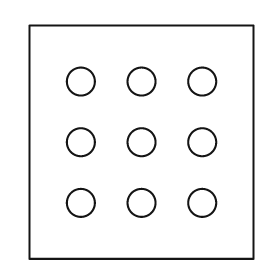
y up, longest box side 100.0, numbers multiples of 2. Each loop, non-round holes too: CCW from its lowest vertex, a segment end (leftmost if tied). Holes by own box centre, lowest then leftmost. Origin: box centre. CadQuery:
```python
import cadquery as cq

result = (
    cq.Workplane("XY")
    .moveTo(-48.0, -50.0)
    .lineTo(48.0, -50.0)
    .lineTo(48.0, 50.0)
    .lineTo(-48.0, 50.0)
    .close()
    .moveTo(-26.0, -26.0)
    .circle(6.0)
    .moveTo(0.0, -26.0)
    .circle(6.0)
    .moveTo(26.0, -26.0)
    .circle(6.0)
    .moveTo(-26.0, 0.0)
    .circle(6.0)
    .moveTo(0.0, 0.0)
    .circle(6.0)
    .moveTo(26.0, 0.0)
    .circle(6.0)
    .moveTo(-26.0, 26.0)
    .circle(6.0)
    .moveTo(0.0, 26.0)
    .circle(6.0)
    .moveTo(26.0, 26.0)
    .circle(6.0)
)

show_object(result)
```